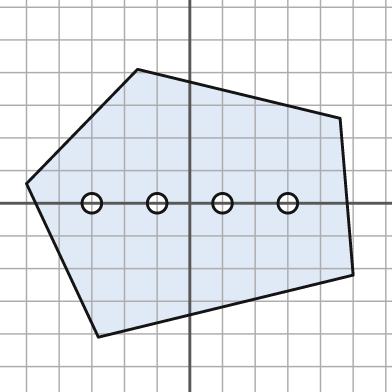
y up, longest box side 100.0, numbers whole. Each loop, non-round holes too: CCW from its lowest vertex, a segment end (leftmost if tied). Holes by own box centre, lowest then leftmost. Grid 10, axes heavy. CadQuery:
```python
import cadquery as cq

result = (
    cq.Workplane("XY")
    .moveTo(-28.0, -41.0)
    .lineTo(50.0, -22.0)
    .lineTo(46.0, 26.0)
    .lineTo(-16.0, 41.0)
    .lineTo(-50.0, 6.0)
    .close()
    .moveTo(-30.0, 0.0)
    .circle(3.0)
    .moveTo(-10.0, 0.0)
    .circle(3.0)
    .moveTo(10.0, 0.0)
    .circle(3.0)
    .moveTo(30.0, 0.0)
    .circle(3.0)
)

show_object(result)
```